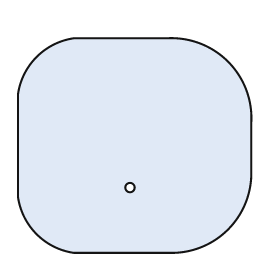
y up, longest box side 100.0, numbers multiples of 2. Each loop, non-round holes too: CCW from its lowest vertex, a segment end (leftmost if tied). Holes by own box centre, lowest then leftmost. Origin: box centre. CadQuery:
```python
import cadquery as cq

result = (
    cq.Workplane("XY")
    .moveTo(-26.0, -46.0)
    .lineTo(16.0, -46.0)
    .threePointArc((40.0, -36.0), (50.0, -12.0))
    .lineTo(50.0, 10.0)
    .threePointArc((40.0, 36.0), (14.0, 46.0))
    .lineTo(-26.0, 46.0)
    .threePointArc((-42.0, 38.0), (-50.0, 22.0))
    .lineTo(-50.0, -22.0)
    .threePointArc((-42.0, -38.0), (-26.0, -46.0))
    .close()
    .moveTo(-2.0, -18.0)
    .circle(2.0)
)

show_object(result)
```